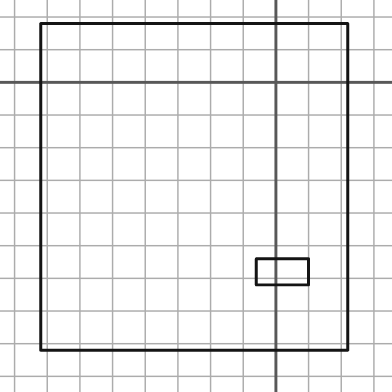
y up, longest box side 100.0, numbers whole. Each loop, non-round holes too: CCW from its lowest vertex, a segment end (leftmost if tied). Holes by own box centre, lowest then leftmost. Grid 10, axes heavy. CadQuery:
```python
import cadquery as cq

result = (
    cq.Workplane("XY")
    .moveTo(-72.0, -82.0)
    .lineTo(22.0, -82.0)
    .lineTo(22.0, 18.0)
    .lineTo(-72.0, 18.0)
    .close()
    .moveTo(-6.0, -62.0)
    .lineTo(10.0, -62.0)
    .lineTo(10.0, -54.0)
    .lineTo(-6.0, -54.0)
    .close()
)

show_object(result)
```